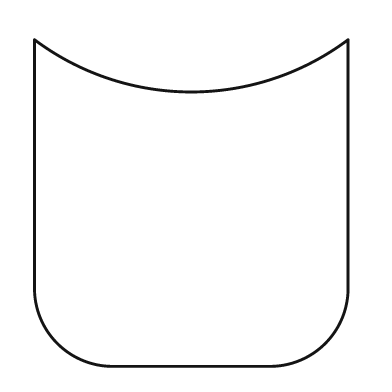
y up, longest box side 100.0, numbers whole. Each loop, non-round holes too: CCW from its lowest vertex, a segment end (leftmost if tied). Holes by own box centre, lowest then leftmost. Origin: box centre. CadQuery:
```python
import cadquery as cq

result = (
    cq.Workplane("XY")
    .moveTo(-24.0, -50.0)
    .lineTo(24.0, -50.0)
    .threePointArc((41.0, -43.0), (48.0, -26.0))
    .lineTo(48.0, 50.0)
    .threePointArc((0.0, 34.0), (-48.0, 50.0))
    .lineTo(-48.0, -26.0)
    .threePointArc((-41.0, -43.0), (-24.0, -50.0))
    .close()
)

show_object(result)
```